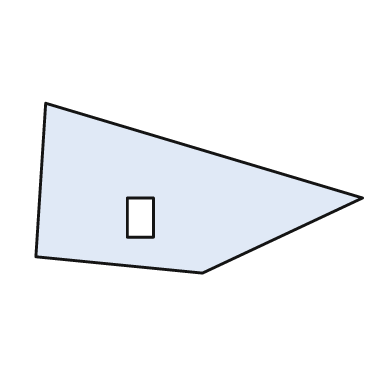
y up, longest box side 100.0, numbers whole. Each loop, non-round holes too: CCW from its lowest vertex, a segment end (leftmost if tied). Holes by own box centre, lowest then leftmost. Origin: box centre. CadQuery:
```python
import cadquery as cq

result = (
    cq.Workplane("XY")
    .moveTo(1.0, -26.0)
    .lineTo(50.0, -3.0)
    .lineTo(-47.0, 26.0)
    .lineTo(-50.0, -21.0)
    .close()
    .moveTo(-22.0, -15.0)
    .lineTo(-14.0, -15.0)
    .lineTo(-14.0, -3.0)
    .lineTo(-22.0, -3.0)
    .close()
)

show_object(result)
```